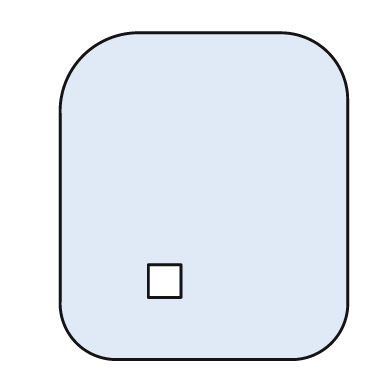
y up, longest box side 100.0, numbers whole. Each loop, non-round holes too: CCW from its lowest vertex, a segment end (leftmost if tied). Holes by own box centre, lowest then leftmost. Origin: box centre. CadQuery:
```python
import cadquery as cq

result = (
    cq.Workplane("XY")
    .moveTo(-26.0, -50.0)
    .lineTo(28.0, -50.0)
    .threePointArc((39.0, -45.0), (44.0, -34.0))
    .lineTo(44.0, 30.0)
    .threePointArc((38.0, 44.0), (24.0, 50.0))
    .lineTo(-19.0, 50.0)
    .threePointArc((-37.0, 43.0), (-44.0, 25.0))
    .lineTo(-44.0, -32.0)
    .threePointArc((-39.0, -45.0), (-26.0, -50.0))
    .close()
    .moveTo(-17.0, -31.0)
    .lineTo(-7.0, -31.0)
    .lineTo(-7.0, -21.0)
    .lineTo(-17.0, -21.0)
    .close()
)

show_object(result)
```